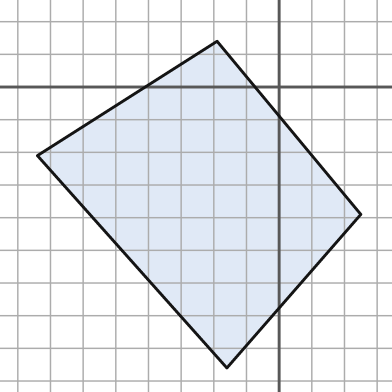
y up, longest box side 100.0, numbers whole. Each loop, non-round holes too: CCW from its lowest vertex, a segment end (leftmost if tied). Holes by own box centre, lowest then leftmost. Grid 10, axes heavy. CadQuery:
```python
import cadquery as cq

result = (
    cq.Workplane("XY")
    .moveTo(-16.0, -86.0)
    .lineTo(25.0, -39.0)
    .lineTo(-19.0, 14.0)
    .lineTo(-74.0, -21.0)
    .close()
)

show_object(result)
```